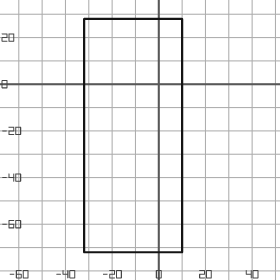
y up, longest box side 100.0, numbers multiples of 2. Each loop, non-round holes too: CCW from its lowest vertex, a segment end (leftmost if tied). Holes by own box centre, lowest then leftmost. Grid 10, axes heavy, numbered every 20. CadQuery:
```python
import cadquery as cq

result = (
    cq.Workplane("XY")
    .moveTo(-32.0, -72.0)
    .lineTo(10.0, -72.0)
    .lineTo(10.0, 28.0)
    .lineTo(-32.0, 28.0)
    .close()
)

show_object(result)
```